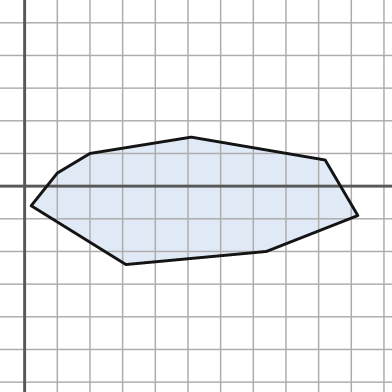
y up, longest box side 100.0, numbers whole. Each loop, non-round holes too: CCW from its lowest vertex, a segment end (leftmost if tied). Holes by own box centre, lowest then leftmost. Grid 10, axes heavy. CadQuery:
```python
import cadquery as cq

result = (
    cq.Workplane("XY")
    .moveTo(31.0, -24.0)
    .lineTo(74.0, -20.0)
    .lineTo(102.0, -9.0)
    .lineTo(92.0, 8.0)
    .lineTo(51.0, 15.0)
    .lineTo(20.0, 10.0)
    .lineTo(10.0, 4.0)
    .lineTo(2.0, -6.0)
    .close()
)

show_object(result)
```